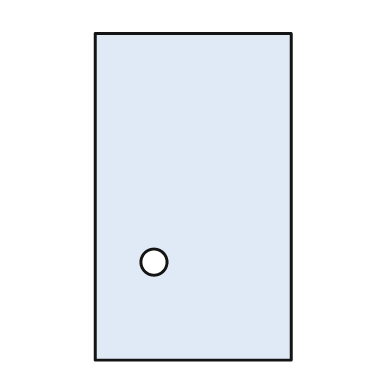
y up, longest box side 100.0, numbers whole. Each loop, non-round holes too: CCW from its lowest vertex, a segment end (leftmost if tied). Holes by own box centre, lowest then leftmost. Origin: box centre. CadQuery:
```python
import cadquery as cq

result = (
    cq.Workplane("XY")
    .moveTo(-30.0, -50.0)
    .lineTo(30.0, -50.0)
    .lineTo(30.0, 50.0)
    .lineTo(-30.0, 50.0)
    .close()
    .moveTo(-12.0, -20.0)
    .circle(4.0)
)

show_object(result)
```